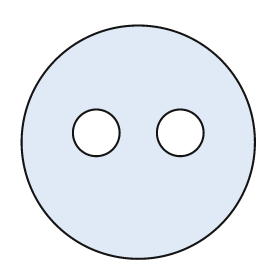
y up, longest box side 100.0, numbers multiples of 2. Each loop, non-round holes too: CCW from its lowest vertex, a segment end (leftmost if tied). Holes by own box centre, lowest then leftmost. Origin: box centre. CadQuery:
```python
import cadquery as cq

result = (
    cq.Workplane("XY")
    .moveTo(0.0, 0.0)
    .circle(50.0)
    .moveTo(-18.0, 4.0)
    .circle(10.0)
    .moveTo(18.0, 4.0)
    .circle(10.0)
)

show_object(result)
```